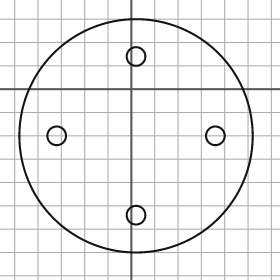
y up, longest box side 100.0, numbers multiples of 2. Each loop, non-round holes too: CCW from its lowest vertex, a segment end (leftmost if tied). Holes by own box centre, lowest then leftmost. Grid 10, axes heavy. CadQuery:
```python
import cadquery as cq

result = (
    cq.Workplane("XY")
    .moveTo(2.0, -20.0)
    .circle(50.0)
    .moveTo(2.0, -54.0)
    .circle(4.0)
    .moveTo(-32.0, -20.0)
    .circle(4.0)
    .moveTo(36.0, -20.0)
    .circle(4.0)
    .moveTo(2.0, 14.0)
    .circle(4.0)
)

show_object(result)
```